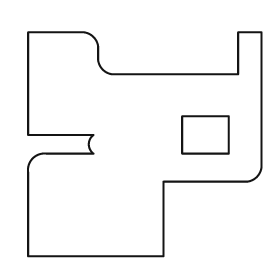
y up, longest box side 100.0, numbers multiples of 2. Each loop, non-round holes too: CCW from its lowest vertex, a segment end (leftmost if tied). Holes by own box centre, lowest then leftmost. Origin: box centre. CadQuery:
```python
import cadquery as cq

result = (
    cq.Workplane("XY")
    .moveTo(-50.0, -48.0)
    .lineTo(8.0, -48.0)
    .lineTo(8.0, -16.0)
    .lineTo(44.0, -16.0)
    .threePointArc((48.0, -14.0), (50.0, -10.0))
    .lineTo(50.0, 48.0)
    .lineTo(40.0, 48.0)
    .lineTo(40.0, 30.0)
    .lineTo(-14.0, 30.0)
    .threePointArc((-18.0, 32.0), (-20.0, 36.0))
    .lineTo(-20.0, 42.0)
    .threePointArc((-22.0, 46.0), (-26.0, 48.0))
    .lineTo(-50.0, 48.0)
    .lineTo(-50.0, 4.0)
    .lineTo(-22.0, 4.0)
    .threePointArc((-24.0, 0.0), (-22.0, -4.0))
    .lineTo(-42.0, -4.0)
    .threePointArc((-48.0, -6.0), (-50.0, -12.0))
    .close()
    .moveTo(16.0, -4.0)
    .lineTo(36.0, -4.0)
    .lineTo(36.0, 12.0)
    .lineTo(16.0, 12.0)
    .close()
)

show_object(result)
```